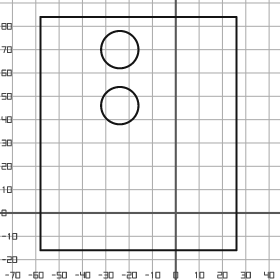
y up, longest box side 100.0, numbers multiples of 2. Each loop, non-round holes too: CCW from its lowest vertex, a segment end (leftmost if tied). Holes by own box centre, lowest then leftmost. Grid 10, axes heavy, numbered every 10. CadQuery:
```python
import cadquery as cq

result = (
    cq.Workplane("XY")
    .moveTo(-58.0, -16.0)
    .lineTo(26.0, -16.0)
    .lineTo(26.0, 84.0)
    .lineTo(-58.0, 84.0)
    .close()
    .moveTo(-24.0, 46.0)
    .circle(8.0)
    .moveTo(-24.0, 70.0)
    .circle(8.0)
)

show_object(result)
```